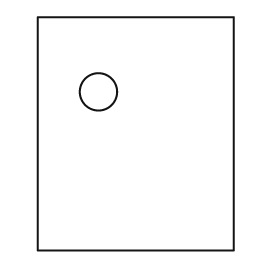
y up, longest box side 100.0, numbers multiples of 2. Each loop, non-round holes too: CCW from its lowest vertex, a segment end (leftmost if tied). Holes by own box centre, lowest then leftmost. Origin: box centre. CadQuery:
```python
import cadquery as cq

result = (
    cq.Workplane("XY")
    .moveTo(-42.0, -50.0)
    .lineTo(42.0, -50.0)
    .lineTo(42.0, 50.0)
    .lineTo(-42.0, 50.0)
    .close()
    .moveTo(-16.0, 18.0)
    .circle(8.0)
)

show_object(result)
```